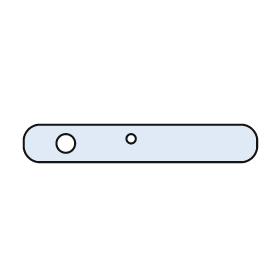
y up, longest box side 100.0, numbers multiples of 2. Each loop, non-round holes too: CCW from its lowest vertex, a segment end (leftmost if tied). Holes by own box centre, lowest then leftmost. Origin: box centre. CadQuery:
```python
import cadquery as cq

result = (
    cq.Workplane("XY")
    .moveTo(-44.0, -8.0)
    .lineTo(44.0, -8.0)
    .threePointArc((48.0, -6.0), (50.0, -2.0))
    .lineTo(50.0, 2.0)
    .threePointArc((48.0, 6.0), (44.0, 8.0))
    .lineTo(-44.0, 8.0)
    .threePointArc((-48.0, 6.0), (-50.0, 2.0))
    .lineTo(-50.0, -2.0)
    .threePointArc((-48.0, -6.0), (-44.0, -8.0))
    .close()
    .moveTo(-32.0, 0.0)
    .circle(4.0)
    .moveTo(-4.0, 2.0)
    .circle(2.0)
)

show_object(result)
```